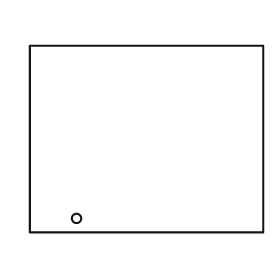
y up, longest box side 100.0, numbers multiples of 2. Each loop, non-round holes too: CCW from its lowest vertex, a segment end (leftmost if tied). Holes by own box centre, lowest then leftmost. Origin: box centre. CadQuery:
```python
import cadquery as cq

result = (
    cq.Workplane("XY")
    .moveTo(-50.0, -40.0)
    .lineTo(50.0, -40.0)
    .lineTo(50.0, 40.0)
    .lineTo(-50.0, 40.0)
    .close()
    .moveTo(-30.0, -34.0)
    .circle(2.0)
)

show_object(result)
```